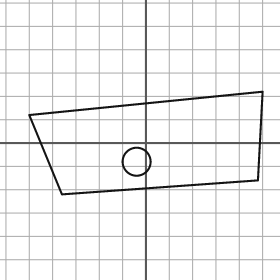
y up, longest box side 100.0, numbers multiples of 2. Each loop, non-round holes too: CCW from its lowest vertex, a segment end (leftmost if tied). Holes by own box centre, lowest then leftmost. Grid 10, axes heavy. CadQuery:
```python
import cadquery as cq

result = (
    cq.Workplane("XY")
    .moveTo(-36.0, -22.0)
    .lineTo(48.0, -16.0)
    .lineTo(50.0, 22.0)
    .lineTo(-50.0, 12.0)
    .close()
    .moveTo(-4.0, -8.0)
    .circle(6.0)
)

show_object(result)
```